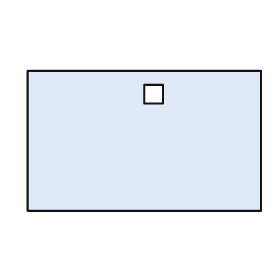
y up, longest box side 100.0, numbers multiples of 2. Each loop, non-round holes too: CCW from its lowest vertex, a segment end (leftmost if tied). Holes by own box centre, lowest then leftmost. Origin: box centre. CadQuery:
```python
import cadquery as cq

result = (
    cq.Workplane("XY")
    .moveTo(-50.0, -30.0)
    .lineTo(50.0, -30.0)
    .lineTo(50.0, 30.0)
    .lineTo(-50.0, 30.0)
    .close()
    .moveTo(0.0, 16.0)
    .lineTo(8.0, 16.0)
    .lineTo(8.0, 24.0)
    .lineTo(0.0, 24.0)
    .close()
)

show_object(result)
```